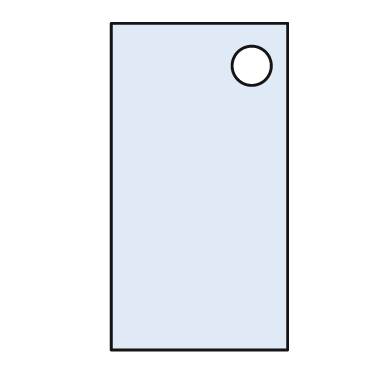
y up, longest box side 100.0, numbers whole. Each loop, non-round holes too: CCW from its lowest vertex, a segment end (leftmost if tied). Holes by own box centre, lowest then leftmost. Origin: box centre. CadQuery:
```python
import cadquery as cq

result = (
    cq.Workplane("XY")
    .moveTo(-27.0, -50.0)
    .lineTo(27.0, -50.0)
    .lineTo(27.0, 50.0)
    .lineTo(-27.0, 50.0)
    .close()
    .moveTo(16.0, 37.0)
    .circle(6.0)
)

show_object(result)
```